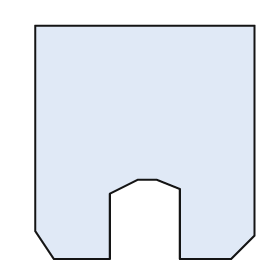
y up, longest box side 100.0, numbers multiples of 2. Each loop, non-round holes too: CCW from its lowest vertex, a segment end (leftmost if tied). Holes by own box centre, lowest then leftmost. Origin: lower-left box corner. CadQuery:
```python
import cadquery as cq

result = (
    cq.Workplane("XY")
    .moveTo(8.0, 0.0)
    .lineTo(32.0, 0.0)
    .lineTo(32.0, 28.0)
    .lineTo(44.0, 34.0)
    .lineTo(52.0, 34.0)
    .lineTo(62.0, 30.0)
    .lineTo(62.0, 0.0)
    .lineTo(84.0, 0.0)
    .lineTo(94.0, 10.0)
    .lineTo(94.0, 100.0)
    .lineTo(0.0, 100.0)
    .lineTo(0.0, 12.0)
    .close()
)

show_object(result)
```